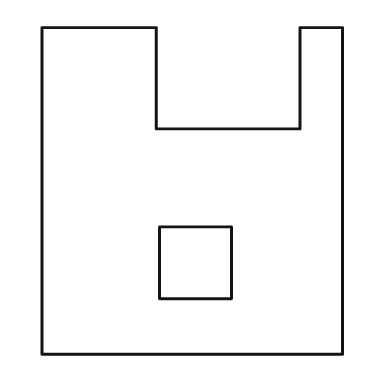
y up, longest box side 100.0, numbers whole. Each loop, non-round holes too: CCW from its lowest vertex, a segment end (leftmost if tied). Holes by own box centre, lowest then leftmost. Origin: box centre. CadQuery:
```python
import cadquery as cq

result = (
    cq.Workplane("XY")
    .moveTo(-46.0, -50.0)
    .lineTo(46.0, -50.0)
    .lineTo(46.0, 50.0)
    .lineTo(33.0, 50.0)
    .lineTo(33.0, 19.0)
    .lineTo(-11.0, 19.0)
    .lineTo(-11.0, 50.0)
    .lineTo(-46.0, 50.0)
    .close()
    .moveTo(-10.0, -33.0)
    .lineTo(12.0, -33.0)
    .lineTo(12.0, -11.0)
    .lineTo(-10.0, -11.0)
    .close()
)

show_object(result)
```